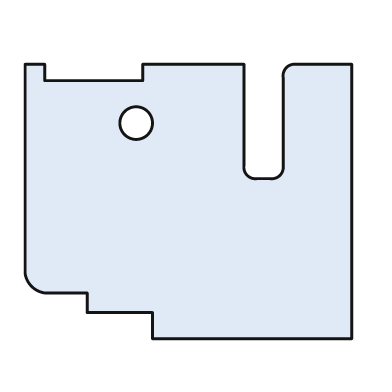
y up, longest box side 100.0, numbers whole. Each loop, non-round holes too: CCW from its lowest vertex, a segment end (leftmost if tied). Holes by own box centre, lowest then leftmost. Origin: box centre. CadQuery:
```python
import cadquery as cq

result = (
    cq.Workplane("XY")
    .moveTo(-11.0, -42.0)
    .lineTo(50.0, -42.0)
    .lineTo(50.0, 42.0)
    .lineTo(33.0, 42.0)
    .threePointArc((30.0, 41.0), (29.0, 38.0))
    .lineTo(29.0, 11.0)
    .threePointArc((28.0, 8.0), (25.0, 7.0))
    .lineTo(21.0, 7.0)
    .threePointArc((18.0, 8.0), (17.0, 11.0))
    .lineTo(17.0, 42.0)
    .lineTo(-14.0, 42.0)
    .lineTo(-14.0, 37.0)
    .lineTo(-44.0, 37.0)
    .lineTo(-44.0, 42.0)
    .lineTo(-50.0, 42.0)
    .lineTo(-50.0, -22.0)
    .threePointArc((-48.0, -26.0), (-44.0, -28.0))
    .lineTo(-31.0, -28.0)
    .lineTo(-31.0, -34.0)
    .lineTo(-11.0, -34.0)
    .close()
    .moveTo(-16.0, 24.0)
    .circle(5.0)
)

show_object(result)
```